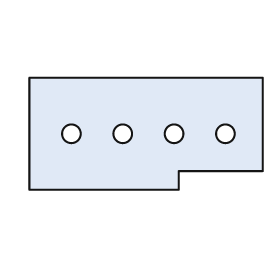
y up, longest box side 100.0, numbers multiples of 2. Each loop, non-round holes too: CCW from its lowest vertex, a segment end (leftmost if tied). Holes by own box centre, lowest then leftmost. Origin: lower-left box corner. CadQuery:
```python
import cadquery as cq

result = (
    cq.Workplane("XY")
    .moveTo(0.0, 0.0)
    .lineTo(64.0, 0.0)
    .lineTo(64.0, 8.0)
    .lineTo(100.0, 8.0)
    .lineTo(100.0, 48.0)
    .lineTo(0.0, 48.0)
    .close()
    .moveTo(18.0, 24.0)
    .circle(4.0)
    .moveTo(40.0, 24.0)
    .circle(4.0)
    .moveTo(62.0, 24.0)
    .circle(4.0)
    .moveTo(84.0, 24.0)
    .circle(4.0)
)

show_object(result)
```